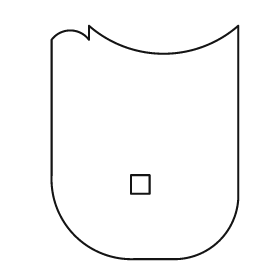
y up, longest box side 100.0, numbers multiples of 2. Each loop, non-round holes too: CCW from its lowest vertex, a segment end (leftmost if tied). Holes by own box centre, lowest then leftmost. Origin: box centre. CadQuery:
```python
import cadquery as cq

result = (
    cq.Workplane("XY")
    .moveTo(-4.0, -50.0)
    .lineTo(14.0, -50.0)
    .threePointArc((32.0, -42.0), (40.0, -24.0))
    .lineTo(40.0, 50.0)
    .threePointArc((8.0, 38.0), (-24.0, 50.0))
    .lineTo(-24.0, 44.0)
    .threePointArc((-32.0, 48.0), (-40.0, 44.0))
    .lineTo(-40.0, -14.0)
    .threePointArc((-30.0, -40.0), (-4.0, -50.0))
    .close()
    .moveTo(-6.0, -22.0)
    .lineTo(2.0, -22.0)
    .lineTo(2.0, -14.0)
    .lineTo(-6.0, -14.0)
    .close()
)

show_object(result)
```